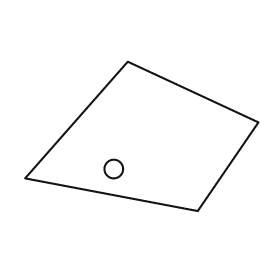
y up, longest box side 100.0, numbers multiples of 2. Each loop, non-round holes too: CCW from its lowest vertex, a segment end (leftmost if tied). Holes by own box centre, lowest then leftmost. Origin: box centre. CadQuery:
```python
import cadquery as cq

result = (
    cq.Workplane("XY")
    .moveTo(24.0, -32.0)
    .lineTo(50.0, 6.0)
    .lineTo(-6.0, 32.0)
    .lineTo(-50.0, -18.0)
    .close()
    .moveTo(-12.0, -14.0)
    .circle(4.0)
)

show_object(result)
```